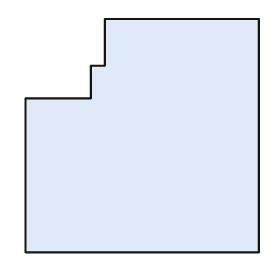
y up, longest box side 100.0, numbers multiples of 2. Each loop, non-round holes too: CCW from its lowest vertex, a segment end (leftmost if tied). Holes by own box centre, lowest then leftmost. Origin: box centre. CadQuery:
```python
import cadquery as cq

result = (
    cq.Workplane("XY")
    .moveTo(-50.0, -50.0)
    .lineTo(50.0, -50.0)
    .lineTo(50.0, 50.0)
    .lineTo(-16.0, 50.0)
    .lineTo(-16.0, 30.0)
    .lineTo(-22.0, 30.0)
    .lineTo(-22.0, 16.0)
    .lineTo(-50.0, 16.0)
    .close()
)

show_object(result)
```